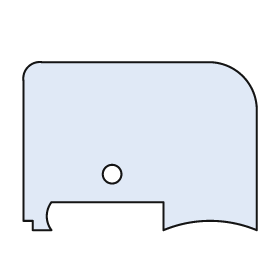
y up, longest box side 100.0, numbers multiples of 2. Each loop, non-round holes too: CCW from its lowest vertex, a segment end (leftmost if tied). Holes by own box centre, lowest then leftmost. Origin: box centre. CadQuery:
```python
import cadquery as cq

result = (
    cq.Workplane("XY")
    .moveTo(-46.0, -36.0)
    .lineTo(-38.0, -36.0)
    .threePointArc((-40.0, -30.0), (-38.0, -24.0))
    .lineTo(10.0, -24.0)
    .lineTo(10.0, -36.0)
    .threePointArc((30.0, -32.0), (50.0, -36.0))
    .lineTo(50.0, 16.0)
    .threePointArc((44.0, 30.0), (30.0, 36.0))
    .lineTo(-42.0, 36.0)
    .threePointArc((-48.0, 34.0), (-50.0, 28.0))
    .lineTo(-50.0, -32.0)
    .lineTo(-46.0, -32.0)
    .close()
    .moveTo(-12.0, -12.0)
    .circle(4.0)
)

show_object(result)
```